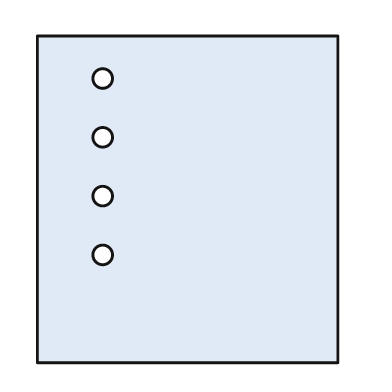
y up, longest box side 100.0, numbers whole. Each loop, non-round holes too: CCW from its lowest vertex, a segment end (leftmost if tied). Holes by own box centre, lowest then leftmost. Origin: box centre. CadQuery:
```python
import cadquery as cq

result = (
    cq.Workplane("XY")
    .moveTo(-46.0, -50.0)
    .lineTo(46.0, -50.0)
    .lineTo(46.0, 50.0)
    .lineTo(-46.0, 50.0)
    .close()
    .moveTo(-26.0, -17.0)
    .circle(3.0)
    .moveTo(-26.0, 1.0)
    .circle(3.0)
    .moveTo(-26.0, 19.0)
    .circle(3.0)
    .moveTo(-26.0, 37.0)
    .circle(3.0)
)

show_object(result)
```